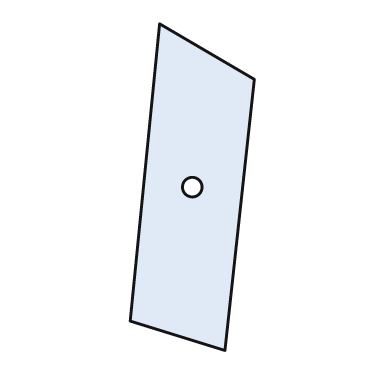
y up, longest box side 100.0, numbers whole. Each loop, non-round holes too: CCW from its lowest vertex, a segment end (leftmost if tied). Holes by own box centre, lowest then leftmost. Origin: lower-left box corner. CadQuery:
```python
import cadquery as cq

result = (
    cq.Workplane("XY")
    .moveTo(29.0, 0.0)
    .lineTo(38.0, 83.0)
    .lineTo(9.0, 100.0)
    .lineTo(0.0, 9.0)
    .close()
    .moveTo(19.0, 50.0)
    .circle(3.0)
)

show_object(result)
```